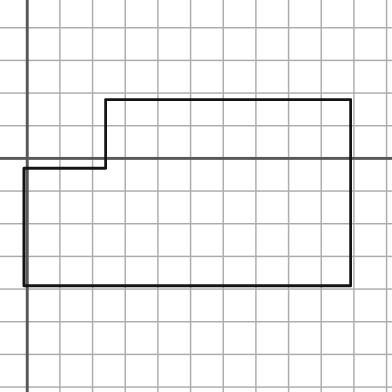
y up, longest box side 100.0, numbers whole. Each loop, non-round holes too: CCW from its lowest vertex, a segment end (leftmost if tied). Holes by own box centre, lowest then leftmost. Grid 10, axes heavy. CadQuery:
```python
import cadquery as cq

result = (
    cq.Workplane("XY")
    .moveTo(-1.0, -39.0)
    .lineTo(99.0, -39.0)
    .lineTo(99.0, 18.0)
    .lineTo(24.0, 18.0)
    .lineTo(24.0, -3.0)
    .lineTo(-1.0, -3.0)
    .close()
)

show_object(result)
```